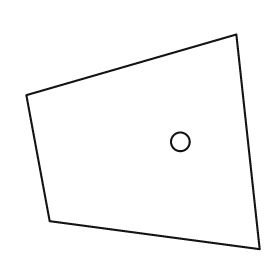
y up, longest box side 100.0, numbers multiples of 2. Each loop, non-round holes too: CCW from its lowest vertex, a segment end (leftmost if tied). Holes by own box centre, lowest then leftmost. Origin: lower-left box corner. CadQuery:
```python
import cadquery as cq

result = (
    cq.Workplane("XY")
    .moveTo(100.0, 0.0)
    .lineTo(90.0, 92.0)
    .lineTo(0.0, 66.0)
    .lineTo(10.0, 12.0)
    .close()
    .moveTo(66.0, 46.0)
    .circle(4.0)
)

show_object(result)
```